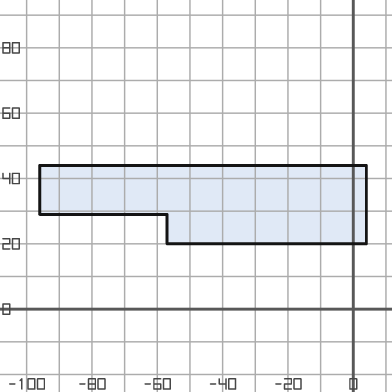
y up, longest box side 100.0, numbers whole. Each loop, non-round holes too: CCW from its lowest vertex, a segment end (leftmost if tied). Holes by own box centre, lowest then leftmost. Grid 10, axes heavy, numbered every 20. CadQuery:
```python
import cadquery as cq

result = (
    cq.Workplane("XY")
    .moveTo(-57.0, 20.0)
    .lineTo(4.0, 20.0)
    .lineTo(4.0, 44.0)
    .lineTo(-96.0, 44.0)
    .lineTo(-96.0, 29.0)
    .lineTo(-57.0, 29.0)
    .close()
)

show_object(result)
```